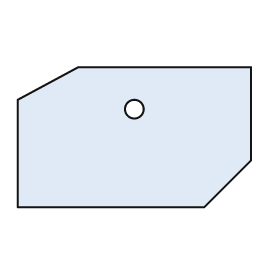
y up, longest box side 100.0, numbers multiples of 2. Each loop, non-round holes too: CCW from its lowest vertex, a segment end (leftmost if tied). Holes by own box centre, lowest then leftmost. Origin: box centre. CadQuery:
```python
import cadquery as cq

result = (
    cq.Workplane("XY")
    .moveTo(-50.0, -30.0)
    .lineTo(30.0, -30.0)
    .lineTo(50.0, -10.0)
    .lineTo(50.0, 30.0)
    .lineTo(-24.0, 30.0)
    .lineTo(-50.0, 16.0)
    .close()
    .moveTo(0.0, 12.0)
    .circle(4.0)
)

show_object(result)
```